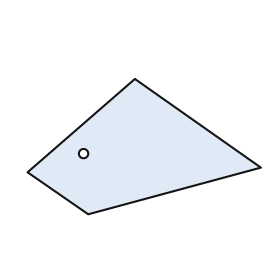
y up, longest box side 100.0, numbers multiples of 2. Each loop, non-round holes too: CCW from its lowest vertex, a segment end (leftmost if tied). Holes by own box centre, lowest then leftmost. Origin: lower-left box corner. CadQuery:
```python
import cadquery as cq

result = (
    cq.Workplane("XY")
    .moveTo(26.0, 0.0)
    .lineTo(100.0, 20.0)
    .lineTo(46.0, 58.0)
    .lineTo(0.0, 18.0)
    .close()
    .moveTo(24.0, 26.0)
    .circle(2.0)
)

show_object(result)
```